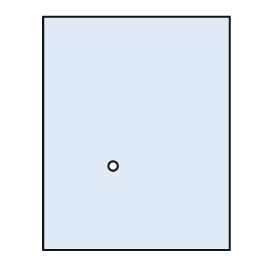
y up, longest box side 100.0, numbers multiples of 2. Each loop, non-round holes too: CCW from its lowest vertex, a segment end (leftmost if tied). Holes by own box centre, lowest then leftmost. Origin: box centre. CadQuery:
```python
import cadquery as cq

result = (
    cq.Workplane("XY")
    .moveTo(-40.0, -50.0)
    .lineTo(40.0, -50.0)
    .lineTo(40.0, 50.0)
    .lineTo(-40.0, 50.0)
    .close()
    .moveTo(-10.0, -14.0)
    .circle(2.0)
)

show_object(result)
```